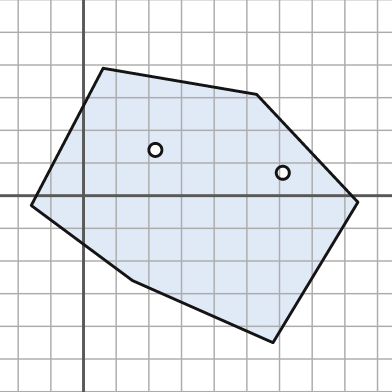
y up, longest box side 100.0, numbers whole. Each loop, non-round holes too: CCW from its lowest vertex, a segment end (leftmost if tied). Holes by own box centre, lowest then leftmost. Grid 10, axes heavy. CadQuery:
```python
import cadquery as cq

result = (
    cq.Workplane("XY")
    .moveTo(58.0, -45.0)
    .lineTo(84.0, -2.0)
    .lineTo(53.0, 31.0)
    .lineTo(6.0, 39.0)
    .lineTo(-16.0, -3.0)
    .lineTo(15.0, -26.0)
    .close()
    .moveTo(61.0, 7.0)
    .circle(2.0)
    .moveTo(22.0, 14.0)
    .circle(2.0)
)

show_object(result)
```